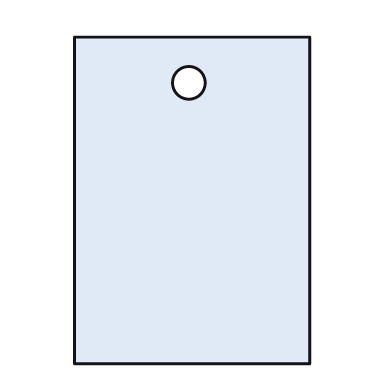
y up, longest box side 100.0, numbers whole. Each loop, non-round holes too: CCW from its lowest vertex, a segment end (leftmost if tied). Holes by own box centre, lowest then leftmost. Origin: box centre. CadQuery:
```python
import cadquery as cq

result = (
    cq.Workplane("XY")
    .moveTo(-36.0, -50.0)
    .lineTo(36.0, -50.0)
    .lineTo(36.0, 50.0)
    .lineTo(-36.0, 50.0)
    .close()
    .moveTo(-1.0, 36.0)
    .circle(5.0)
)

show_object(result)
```